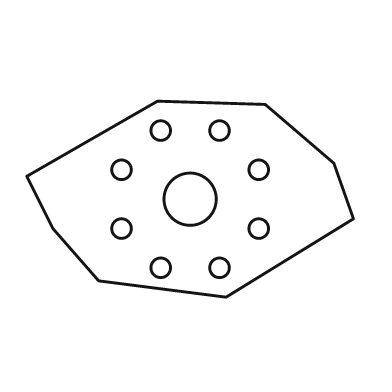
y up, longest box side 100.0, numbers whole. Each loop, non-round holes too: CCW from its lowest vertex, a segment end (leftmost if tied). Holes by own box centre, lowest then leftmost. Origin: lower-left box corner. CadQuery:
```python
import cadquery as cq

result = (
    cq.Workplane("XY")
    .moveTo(61.0, 0.0)
    .lineTo(100.0, 24.0)
    .lineTo(94.0, 41.0)
    .lineTo(73.0, 59.0)
    .lineTo(40.0, 60.0)
    .lineTo(0.0, 37.0)
    .lineTo(8.0, 21.0)
    .lineTo(22.0, 5.0)
    .close()
    .moveTo(41.0, 9.0)
    .circle(3.0)
    .moveTo(59.0, 9.0)
    .circle(3.0)
    .moveTo(29.0, 21.0)
    .circle(3.0)
    .moveTo(71.0, 21.0)
    .circle(3.0)
    .moveTo(50.0, 30.0)
    .circle(8.0)
    .moveTo(29.0, 39.0)
    .circle(3.0)
    .moveTo(71.0, 39.0)
    .circle(3.0)
    .moveTo(41.0, 51.0)
    .circle(3.0)
    .moveTo(59.0, 51.0)
    .circle(3.0)
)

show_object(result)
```